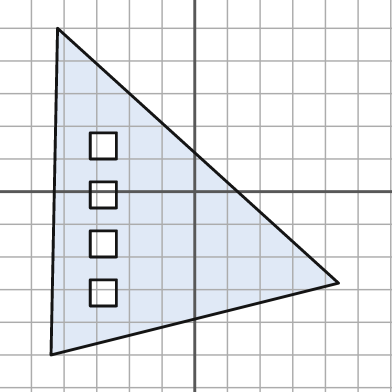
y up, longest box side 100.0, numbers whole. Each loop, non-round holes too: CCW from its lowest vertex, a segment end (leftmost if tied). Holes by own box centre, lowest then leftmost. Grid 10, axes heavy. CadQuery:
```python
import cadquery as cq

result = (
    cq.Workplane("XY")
    .moveTo(-44.0, -50.0)
    .lineTo(44.0, -28.0)
    .lineTo(-42.0, 50.0)
    .close()
    .moveTo(-32.0, -35.0)
    .lineTo(-24.0, -35.0)
    .lineTo(-24.0, -27.0)
    .lineTo(-32.0, -27.0)
    .close()
    .moveTo(-32.0, -20.0)
    .lineTo(-24.0, -20.0)
    .lineTo(-24.0, -12.0)
    .lineTo(-32.0, -12.0)
    .close()
    .moveTo(-32.0, -5.0)
    .lineTo(-24.0, -5.0)
    .lineTo(-24.0, 3.0)
    .lineTo(-32.0, 3.0)
    .close()
    .moveTo(-32.0, 10.0)
    .lineTo(-24.0, 10.0)
    .lineTo(-24.0, 18.0)
    .lineTo(-32.0, 18.0)
    .close()
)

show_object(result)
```